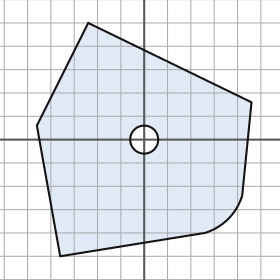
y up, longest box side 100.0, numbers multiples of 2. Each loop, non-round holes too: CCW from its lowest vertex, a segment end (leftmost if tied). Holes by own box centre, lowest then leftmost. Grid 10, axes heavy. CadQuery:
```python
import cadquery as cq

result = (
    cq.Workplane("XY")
    .moveTo(-36.0, -50.0)
    .lineTo(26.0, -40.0)
    .threePointArc((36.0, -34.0), (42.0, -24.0))
    .lineTo(46.0, 16.0)
    .lineTo(-24.0, 50.0)
    .lineTo(-46.0, 6.0)
    .close()
    .moveTo(0.0, 0.0)
    .circle(6.0)
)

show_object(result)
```